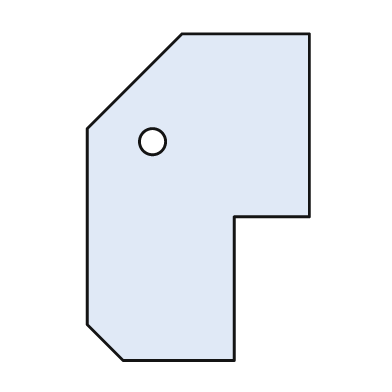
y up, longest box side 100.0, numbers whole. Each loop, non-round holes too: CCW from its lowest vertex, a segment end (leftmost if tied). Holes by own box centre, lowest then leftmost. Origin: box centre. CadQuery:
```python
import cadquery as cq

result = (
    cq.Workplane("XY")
    .moveTo(-23.0, -50.0)
    .lineTo(11.0, -50.0)
    .lineTo(11.0, -6.0)
    .lineTo(34.0, -6.0)
    .lineTo(34.0, 50.0)
    .lineTo(-5.0, 50.0)
    .lineTo(-34.0, 21.0)
    .lineTo(-34.0, -39.0)
    .close()
    .moveTo(-14.0, 17.0)
    .circle(4.0)
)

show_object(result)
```